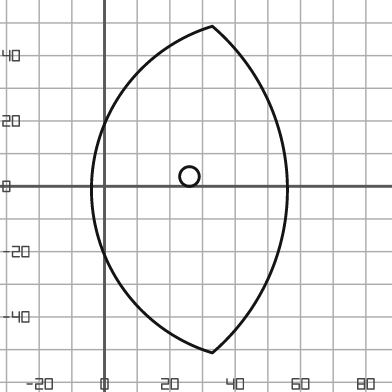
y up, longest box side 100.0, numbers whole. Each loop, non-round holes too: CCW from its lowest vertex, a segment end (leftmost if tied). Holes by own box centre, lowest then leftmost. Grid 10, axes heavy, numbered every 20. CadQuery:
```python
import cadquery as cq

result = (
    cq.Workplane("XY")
    .moveTo(33.0, -51.0)
    .threePointArc((56.0, -1.0), (33.0, 49.0))
    .threePointArc((-4.0, -1.0), (33.0, -51.0))
    .close()
    .moveTo(26.0, 3.0)
    .circle(3.0)
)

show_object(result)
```